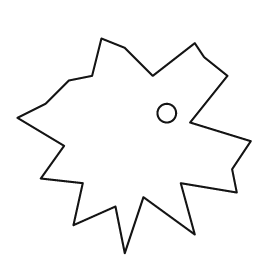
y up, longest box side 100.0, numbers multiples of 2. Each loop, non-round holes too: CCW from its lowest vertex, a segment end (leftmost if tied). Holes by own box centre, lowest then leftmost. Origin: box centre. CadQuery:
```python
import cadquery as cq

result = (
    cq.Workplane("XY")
    .moveTo(-4.0, -46.0)
    .lineTo(4.0, -22.0)
    .lineTo(26.0, -38.0)
    .lineTo(20.0, -16.0)
    .lineTo(44.0, -20.0)
    .lineTo(42.0, -10.0)
    .lineTo(50.0, 2.0)
    .lineTo(24.0, 10.0)
    .lineTo(40.0, 30.0)
    .lineTo(30.0, 38.0)
    .lineTo(26.0, 44.0)
    .lineTo(8.0, 30.0)
    .lineTo(-4.0, 42.0)
    .lineTo(-14.0, 46.0)
    .lineTo(-18.0, 30.0)
    .lineTo(-28.0, 28.0)
    .lineTo(-38.0, 18.0)
    .lineTo(-50.0, 12.0)
    .lineTo(-30.0, 0.0)
    .lineTo(-40.0, -14.0)
    .lineTo(-22.0, -16.0)
    .lineTo(-26.0, -34.0)
    .lineTo(-8.0, -26.0)
    .close()
    .moveTo(14.0, 14.0)
    .circle(4.0)
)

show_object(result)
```